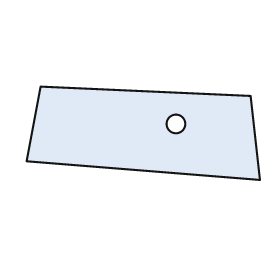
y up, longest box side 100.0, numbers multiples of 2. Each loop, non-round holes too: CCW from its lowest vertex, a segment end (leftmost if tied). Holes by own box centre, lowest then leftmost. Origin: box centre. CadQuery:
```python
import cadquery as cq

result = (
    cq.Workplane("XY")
    .moveTo(50.0, -20.0)
    .lineTo(46.0, 16.0)
    .lineTo(-44.0, 20.0)
    .lineTo(-50.0, -12.0)
    .close()
    .moveTo(14.0, 4.0)
    .circle(4.0)
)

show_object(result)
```